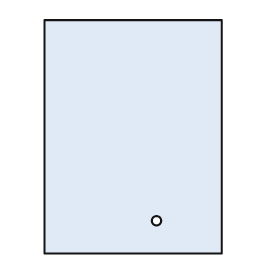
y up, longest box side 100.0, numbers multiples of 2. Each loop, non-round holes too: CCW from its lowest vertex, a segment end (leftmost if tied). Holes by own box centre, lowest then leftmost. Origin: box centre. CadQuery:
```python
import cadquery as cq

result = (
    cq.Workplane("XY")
    .moveTo(-38.0, -50.0)
    .lineTo(38.0, -50.0)
    .lineTo(38.0, 50.0)
    .lineTo(-38.0, 50.0)
    .close()
    .moveTo(10.0, -36.0)
    .circle(2.0)
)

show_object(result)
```